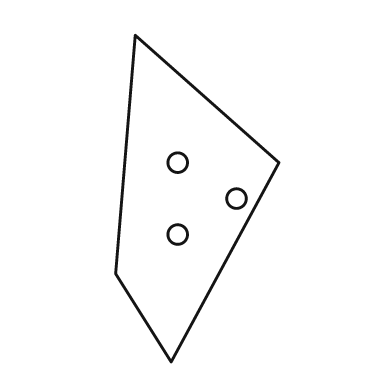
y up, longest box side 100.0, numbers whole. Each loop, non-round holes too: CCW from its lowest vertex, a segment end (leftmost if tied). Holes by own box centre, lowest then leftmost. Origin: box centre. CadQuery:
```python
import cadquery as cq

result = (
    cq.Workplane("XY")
    .moveTo(-8.0, -50.0)
    .lineTo(25.0, 11.0)
    .lineTo(-19.0, 50.0)
    .lineTo(-25.0, -23.0)
    .close()
    .moveTo(-6.0, -11.0)
    .circle(3.0)
    .moveTo(12.0, 0.0)
    .circle(3.0)
    .moveTo(-6.0, 11.0)
    .circle(3.0)
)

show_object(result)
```